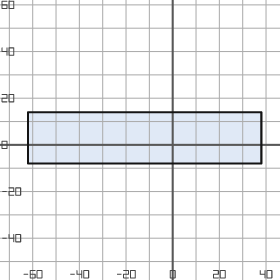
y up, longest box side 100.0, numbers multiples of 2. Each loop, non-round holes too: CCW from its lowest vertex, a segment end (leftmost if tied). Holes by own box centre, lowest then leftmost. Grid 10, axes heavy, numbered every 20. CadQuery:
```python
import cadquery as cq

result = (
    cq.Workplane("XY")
    .moveTo(-62.0, -8.0)
    .lineTo(38.0, -8.0)
    .lineTo(38.0, 14.0)
    .lineTo(-62.0, 14.0)
    .close()
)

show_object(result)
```